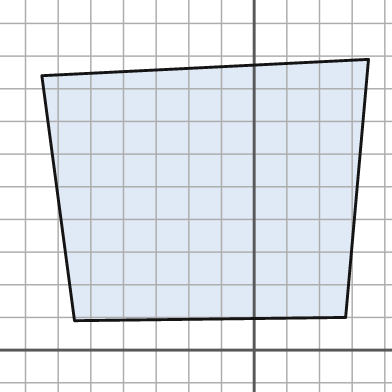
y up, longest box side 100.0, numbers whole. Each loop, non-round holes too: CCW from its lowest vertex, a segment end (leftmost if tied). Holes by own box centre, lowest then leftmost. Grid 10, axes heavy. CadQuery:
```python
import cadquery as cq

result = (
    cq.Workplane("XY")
    .moveTo(-55.0, 9.0)
    .lineTo(28.0, 10.0)
    .lineTo(35.0, 89.0)
    .lineTo(-65.0, 84.0)
    .close()
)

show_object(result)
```